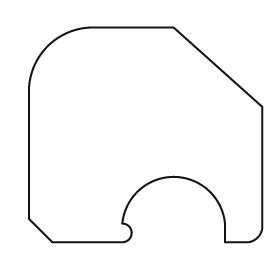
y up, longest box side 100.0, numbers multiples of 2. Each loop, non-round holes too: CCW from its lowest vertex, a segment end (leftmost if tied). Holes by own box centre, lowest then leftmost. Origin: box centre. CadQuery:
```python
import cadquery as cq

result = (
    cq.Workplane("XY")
    .moveTo(-40.0, -46.0)
    .lineTo(-10.0, -46.0)
    .threePointArc((-6.0, -42.0), (-10.0, -38.0))
    .threePointArc((12.0, -18.0), (34.0, -38.0))
    .lineTo(34.0, -46.0)
    .lineTo(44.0, -46.0)
    .threePointArc((48.0, -44.0), (50.0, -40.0))
    .lineTo(50.0, 12.0)
    .lineTo(12.0, 46.0)
    .lineTo(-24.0, 46.0)
    .threePointArc((-42.0, 38.0), (-50.0, 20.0))
    .lineTo(-50.0, -36.0)
    .close()
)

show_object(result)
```